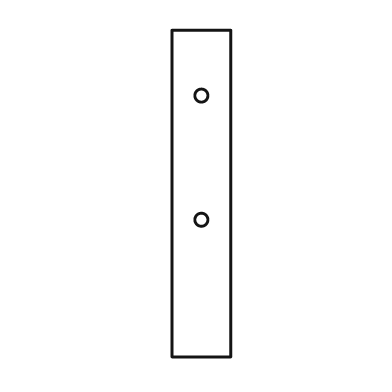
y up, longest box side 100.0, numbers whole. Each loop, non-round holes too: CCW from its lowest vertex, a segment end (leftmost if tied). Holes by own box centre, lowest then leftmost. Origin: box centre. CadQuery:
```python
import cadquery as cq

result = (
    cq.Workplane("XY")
    .moveTo(-9.0, -50.0)
    .lineTo(9.0, -50.0)
    .lineTo(9.0, 50.0)
    .lineTo(-9.0, 50.0)
    .close()
    .moveTo(0.0, -8.0)
    .circle(2.0)
    .moveTo(0.0, 30.0)
    .circle(2.0)
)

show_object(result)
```